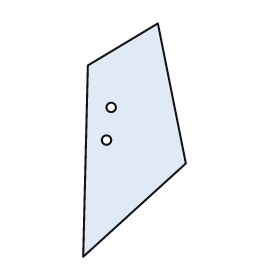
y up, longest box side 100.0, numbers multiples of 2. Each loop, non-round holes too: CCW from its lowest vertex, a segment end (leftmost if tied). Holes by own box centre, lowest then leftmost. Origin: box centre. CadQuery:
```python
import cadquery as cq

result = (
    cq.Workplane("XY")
    .moveTo(-22.0, -50.0)
    .lineTo(22.0, -10.0)
    .lineTo(10.0, 50.0)
    .lineTo(-20.0, 32.0)
    .close()
    .moveTo(-12.0, 0.0)
    .circle(2.0)
    .moveTo(-10.0, 14.0)
    .circle(2.0)
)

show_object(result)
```